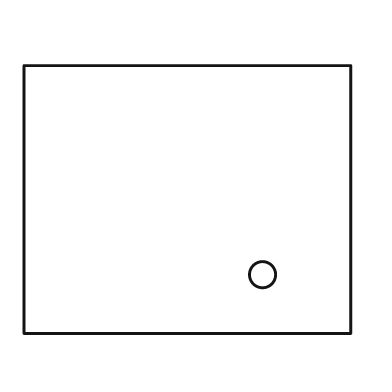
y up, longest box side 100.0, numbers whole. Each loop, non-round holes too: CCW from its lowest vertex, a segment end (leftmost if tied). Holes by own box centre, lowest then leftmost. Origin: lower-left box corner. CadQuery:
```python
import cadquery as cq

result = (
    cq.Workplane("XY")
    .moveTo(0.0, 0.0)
    .lineTo(100.0, 0.0)
    .lineTo(100.0, 82.0)
    .lineTo(0.0, 82.0)
    .close()
    .moveTo(73.0, 18.0)
    .circle(4.0)
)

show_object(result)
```